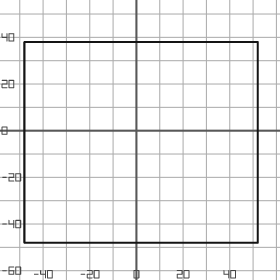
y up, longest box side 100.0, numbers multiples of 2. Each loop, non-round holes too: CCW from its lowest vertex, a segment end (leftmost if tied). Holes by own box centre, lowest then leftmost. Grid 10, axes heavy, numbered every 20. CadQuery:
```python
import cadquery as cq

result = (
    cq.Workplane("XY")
    .moveTo(-48.0, -48.0)
    .lineTo(52.0, -48.0)
    .lineTo(52.0, 38.0)
    .lineTo(-48.0, 38.0)
    .close()
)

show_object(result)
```